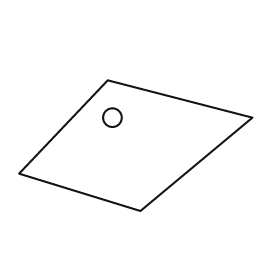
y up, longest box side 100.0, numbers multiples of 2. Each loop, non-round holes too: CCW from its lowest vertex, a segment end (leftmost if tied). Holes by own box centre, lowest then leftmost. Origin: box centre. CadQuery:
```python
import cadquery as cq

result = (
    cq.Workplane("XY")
    .moveTo(2.0, -28.0)
    .lineTo(50.0, 12.0)
    .lineTo(-12.0, 28.0)
    .lineTo(-50.0, -12.0)
    .close()
    .moveTo(-10.0, 12.0)
    .circle(4.0)
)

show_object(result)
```